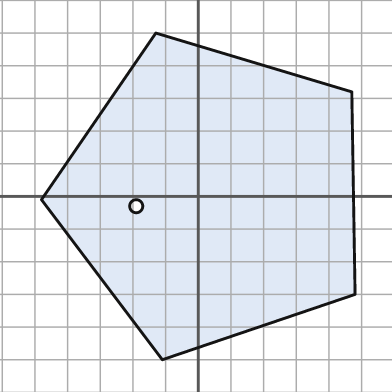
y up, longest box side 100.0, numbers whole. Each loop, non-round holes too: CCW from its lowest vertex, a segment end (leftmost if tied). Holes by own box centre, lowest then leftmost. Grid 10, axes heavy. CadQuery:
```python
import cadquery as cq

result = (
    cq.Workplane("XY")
    .moveTo(-11.0, -50.0)
    .lineTo(48.0, -30.0)
    .lineTo(47.0, 32.0)
    .lineTo(-13.0, 50.0)
    .lineTo(-48.0, -1.0)
    .close()
    .moveTo(-19.0, -3.0)
    .circle(2.0)
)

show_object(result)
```